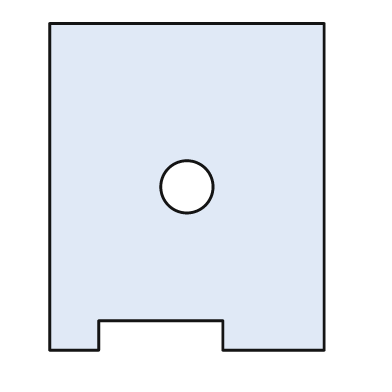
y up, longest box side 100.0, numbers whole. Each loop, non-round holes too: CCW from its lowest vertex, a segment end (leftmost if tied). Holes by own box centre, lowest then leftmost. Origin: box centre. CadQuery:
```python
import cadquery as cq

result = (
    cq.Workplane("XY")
    .moveTo(-42.0, -50.0)
    .lineTo(-27.0, -50.0)
    .lineTo(-27.0, -41.0)
    .lineTo(11.0, -41.0)
    .lineTo(11.0, -50.0)
    .lineTo(42.0, -50.0)
    .lineTo(42.0, 50.0)
    .lineTo(-42.0, 50.0)
    .close()
    .moveTo(0.0, 0.0)
    .circle(8.0)
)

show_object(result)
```